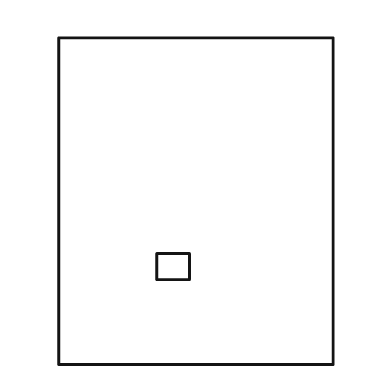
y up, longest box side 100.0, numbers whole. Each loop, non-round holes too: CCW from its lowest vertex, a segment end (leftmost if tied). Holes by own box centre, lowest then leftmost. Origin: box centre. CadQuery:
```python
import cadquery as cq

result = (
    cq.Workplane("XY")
    .moveTo(-42.0, -50.0)
    .lineTo(42.0, -50.0)
    .lineTo(42.0, 50.0)
    .lineTo(-42.0, 50.0)
    .close()
    .moveTo(-12.0, -24.0)
    .lineTo(-2.0, -24.0)
    .lineTo(-2.0, -16.0)
    .lineTo(-12.0, -16.0)
    .close()
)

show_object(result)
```